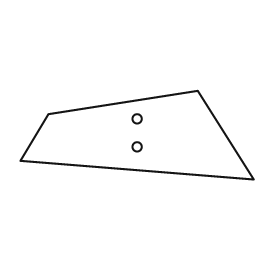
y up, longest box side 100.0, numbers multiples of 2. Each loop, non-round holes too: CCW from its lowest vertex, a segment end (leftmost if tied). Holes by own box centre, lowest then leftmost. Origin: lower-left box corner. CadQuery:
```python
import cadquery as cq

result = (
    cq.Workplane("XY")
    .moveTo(100.0, 0.0)
    .lineTo(76.0, 38.0)
    .lineTo(12.0, 28.0)
    .lineTo(0.0, 8.0)
    .close()
    .moveTo(50.0, 14.0)
    .circle(2.0)
    .moveTo(50.0, 26.0)
    .circle(2.0)
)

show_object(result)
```